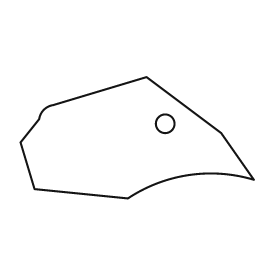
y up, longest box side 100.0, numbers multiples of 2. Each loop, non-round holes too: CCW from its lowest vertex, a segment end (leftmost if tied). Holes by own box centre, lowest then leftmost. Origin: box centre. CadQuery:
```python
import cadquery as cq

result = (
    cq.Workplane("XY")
    .moveTo(-4.0, -26.0)
    .threePointArc((22.0, -16.0), (50.0, -18.0))
    .lineTo(36.0, 2.0)
    .lineTo(4.0, 26.0)
    .lineTo(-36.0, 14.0)
    .threePointArc((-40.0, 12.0), (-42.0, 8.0))
    .lineTo(-50.0, -2.0)
    .lineTo(-44.0, -22.0)
    .close()
    .moveTo(12.0, 6.0)
    .circle(4.0)
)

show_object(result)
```